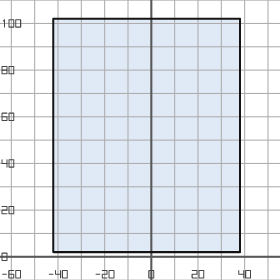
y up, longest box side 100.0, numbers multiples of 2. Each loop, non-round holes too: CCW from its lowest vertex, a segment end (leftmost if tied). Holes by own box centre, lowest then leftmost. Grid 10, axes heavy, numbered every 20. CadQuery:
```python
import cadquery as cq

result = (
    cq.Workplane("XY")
    .moveTo(-42.0, 2.0)
    .lineTo(38.0, 2.0)
    .lineTo(38.0, 102.0)
    .lineTo(-42.0, 102.0)
    .close()
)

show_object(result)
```